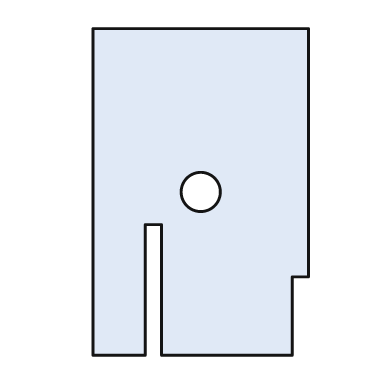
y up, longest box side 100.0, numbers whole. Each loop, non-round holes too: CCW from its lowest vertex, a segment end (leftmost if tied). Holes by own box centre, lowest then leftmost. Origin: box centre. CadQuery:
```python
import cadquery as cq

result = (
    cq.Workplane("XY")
    .moveTo(-33.0, -50.0)
    .lineTo(-17.0, -50.0)
    .lineTo(-17.0, -10.0)
    .lineTo(-12.0, -10.0)
    .lineTo(-12.0, -50.0)
    .lineTo(28.0, -50.0)
    .lineTo(28.0, -26.0)
    .lineTo(33.0, -26.0)
    .lineTo(33.0, 50.0)
    .lineTo(-33.0, 50.0)
    .close()
    .moveTo(0.0, 0.0)
    .circle(6.0)
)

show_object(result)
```